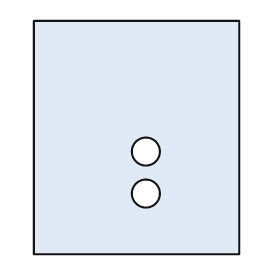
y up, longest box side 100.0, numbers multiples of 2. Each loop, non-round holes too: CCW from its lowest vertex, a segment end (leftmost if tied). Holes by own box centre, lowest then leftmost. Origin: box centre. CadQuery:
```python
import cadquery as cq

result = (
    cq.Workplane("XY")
    .moveTo(-44.0, -50.0)
    .lineTo(44.0, -50.0)
    .lineTo(44.0, 50.0)
    .lineTo(-44.0, 50.0)
    .close()
    .moveTo(4.0, -24.0)
    .circle(6.0)
    .moveTo(4.0, -6.0)
    .circle(6.0)
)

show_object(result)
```